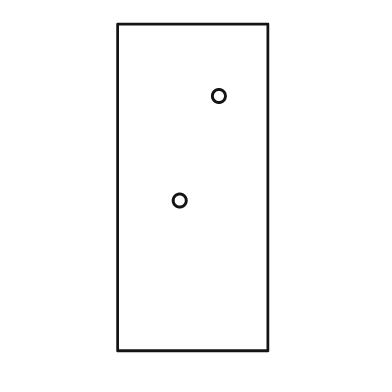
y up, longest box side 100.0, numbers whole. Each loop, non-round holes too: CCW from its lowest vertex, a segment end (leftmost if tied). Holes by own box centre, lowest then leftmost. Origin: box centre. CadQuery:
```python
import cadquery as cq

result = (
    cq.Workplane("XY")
    .moveTo(-23.0, -50.0)
    .lineTo(23.0, -50.0)
    .lineTo(23.0, 50.0)
    .lineTo(-23.0, 50.0)
    .close()
    .moveTo(-4.0, -4.0)
    .circle(2.0)
    .moveTo(8.0, 28.0)
    .circle(2.0)
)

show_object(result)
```